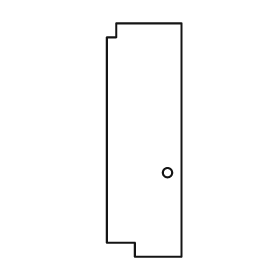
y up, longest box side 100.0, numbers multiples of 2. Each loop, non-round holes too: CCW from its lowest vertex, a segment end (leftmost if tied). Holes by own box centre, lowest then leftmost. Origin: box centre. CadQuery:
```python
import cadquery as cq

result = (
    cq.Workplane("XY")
    .moveTo(-4.0, -50.0)
    .lineTo(16.0, -50.0)
    .lineTo(16.0, 50.0)
    .lineTo(-12.0, 50.0)
    .lineTo(-12.0, 44.0)
    .lineTo(-16.0, 44.0)
    .lineTo(-16.0, -44.0)
    .lineTo(-4.0, -44.0)
    .close()
    .moveTo(10.0, -14.0)
    .circle(2.0)
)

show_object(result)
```